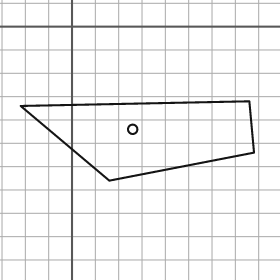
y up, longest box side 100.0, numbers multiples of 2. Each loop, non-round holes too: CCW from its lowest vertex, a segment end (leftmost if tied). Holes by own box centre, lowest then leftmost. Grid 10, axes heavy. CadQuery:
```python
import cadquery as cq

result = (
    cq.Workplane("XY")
    .moveTo(16.0, -66.0)
    .lineTo(78.0, -54.0)
    .lineTo(76.0, -32.0)
    .lineTo(-22.0, -34.0)
    .close()
    .moveTo(26.0, -44.0)
    .circle(2.0)
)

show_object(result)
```